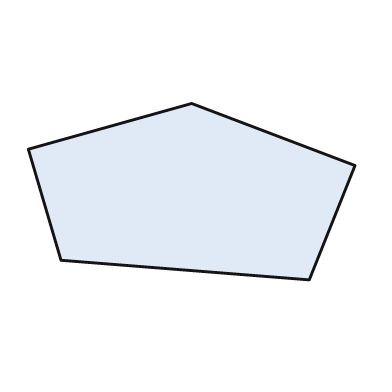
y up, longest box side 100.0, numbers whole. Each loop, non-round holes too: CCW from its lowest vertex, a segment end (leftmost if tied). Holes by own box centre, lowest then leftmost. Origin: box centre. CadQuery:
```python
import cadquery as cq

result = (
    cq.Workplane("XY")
    .moveTo(36.0, -27.0)
    .lineTo(50.0, 8.0)
    .lineTo(0.0, 27.0)
    .lineTo(-50.0, 13.0)
    .lineTo(-40.0, -21.0)
    .close()
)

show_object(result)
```